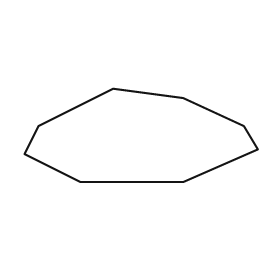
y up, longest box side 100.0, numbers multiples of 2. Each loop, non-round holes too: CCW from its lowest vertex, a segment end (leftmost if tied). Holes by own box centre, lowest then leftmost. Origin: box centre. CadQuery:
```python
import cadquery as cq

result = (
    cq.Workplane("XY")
    .moveTo(-26.0, -20.0)
    .lineTo(18.0, -20.0)
    .lineTo(50.0, -6.0)
    .lineTo(44.0, 4.0)
    .lineTo(18.0, 16.0)
    .lineTo(-12.0, 20.0)
    .lineTo(-44.0, 4.0)
    .lineTo(-50.0, -8.0)
    .close()
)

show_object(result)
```